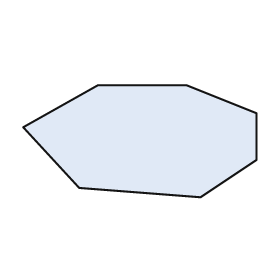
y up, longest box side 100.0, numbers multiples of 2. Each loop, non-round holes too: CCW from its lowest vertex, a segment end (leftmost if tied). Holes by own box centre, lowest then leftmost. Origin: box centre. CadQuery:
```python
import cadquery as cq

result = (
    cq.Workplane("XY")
    .moveTo(26.0, -24.0)
    .lineTo(50.0, -8.0)
    .lineTo(50.0, 12.0)
    .lineTo(20.0, 24.0)
    .lineTo(-18.0, 24.0)
    .lineTo(-50.0, 6.0)
    .lineTo(-26.0, -20.0)
    .close()
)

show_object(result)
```